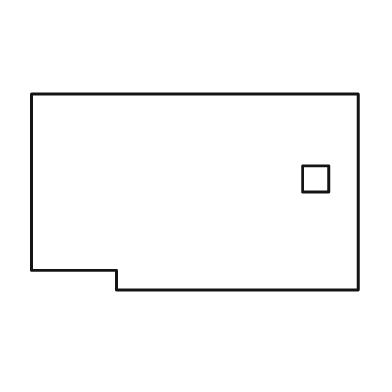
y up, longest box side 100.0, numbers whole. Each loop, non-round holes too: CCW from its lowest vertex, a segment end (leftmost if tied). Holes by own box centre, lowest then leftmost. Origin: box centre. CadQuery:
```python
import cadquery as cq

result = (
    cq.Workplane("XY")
    .moveTo(-24.0, -30.0)
    .lineTo(50.0, -30.0)
    .lineTo(50.0, 30.0)
    .lineTo(-50.0, 30.0)
    .lineTo(-50.0, -24.0)
    .lineTo(-24.0, -24.0)
    .close()
    .moveTo(33.0, 0.0)
    .lineTo(41.0, 0.0)
    .lineTo(41.0, 8.0)
    .lineTo(33.0, 8.0)
    .close()
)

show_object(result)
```